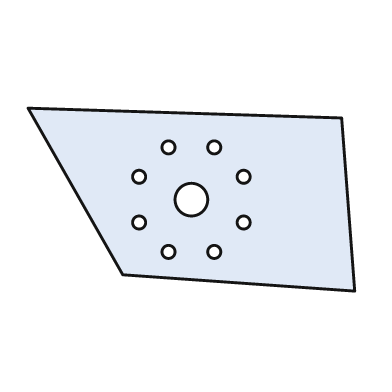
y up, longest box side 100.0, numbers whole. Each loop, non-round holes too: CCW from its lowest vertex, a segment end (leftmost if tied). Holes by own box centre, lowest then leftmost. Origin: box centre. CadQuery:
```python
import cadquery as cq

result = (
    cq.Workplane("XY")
    .moveTo(50.0, -28.0)
    .lineTo(46.0, 25.0)
    .lineTo(-50.0, 28.0)
    .lineTo(-21.0, -23.0)
    .close()
    .moveTo(-7.0, -16.0)
    .circle(2.0)
    .moveTo(7.0, -16.0)
    .circle(2.0)
    .moveTo(-16.0, -7.0)
    .circle(2.0)
    .moveTo(16.0, -7.0)
    .circle(2.0)
    .moveTo(0.0, 0.0)
    .circle(5.0)
    .moveTo(-16.0, 7.0)
    .circle(2.0)
    .moveTo(16.0, 7.0)
    .circle(2.0)
    .moveTo(-7.0, 16.0)
    .circle(2.0)
    .moveTo(7.0, 16.0)
    .circle(2.0)
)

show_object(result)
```